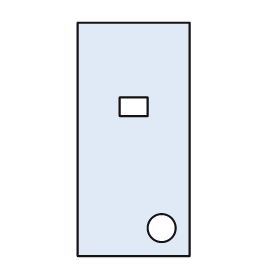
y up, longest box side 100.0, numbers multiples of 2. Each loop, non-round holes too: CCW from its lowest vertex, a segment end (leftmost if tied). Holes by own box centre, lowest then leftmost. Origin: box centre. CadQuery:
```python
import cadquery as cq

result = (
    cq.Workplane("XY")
    .moveTo(-24.0, -50.0)
    .lineTo(24.0, -50.0)
    .lineTo(24.0, 50.0)
    .lineTo(-24.0, 50.0)
    .close()
    .moveTo(12.0, -38.0)
    .circle(6.0)
    .moveTo(-6.0, 10.0)
    .lineTo(6.0, 10.0)
    .lineTo(6.0, 18.0)
    .lineTo(-6.0, 18.0)
    .close()
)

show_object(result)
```